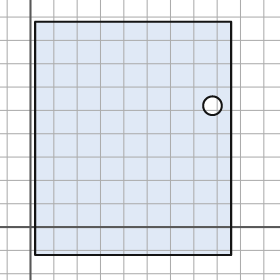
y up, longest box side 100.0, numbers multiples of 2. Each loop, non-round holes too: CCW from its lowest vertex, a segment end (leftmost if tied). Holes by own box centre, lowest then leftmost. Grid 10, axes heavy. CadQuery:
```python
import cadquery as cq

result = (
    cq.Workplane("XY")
    .moveTo(2.0, -12.0)
    .lineTo(86.0, -12.0)
    .lineTo(86.0, 88.0)
    .lineTo(2.0, 88.0)
    .close()
    .moveTo(78.0, 52.0)
    .circle(4.0)
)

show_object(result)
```